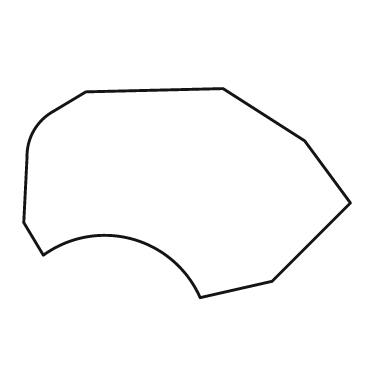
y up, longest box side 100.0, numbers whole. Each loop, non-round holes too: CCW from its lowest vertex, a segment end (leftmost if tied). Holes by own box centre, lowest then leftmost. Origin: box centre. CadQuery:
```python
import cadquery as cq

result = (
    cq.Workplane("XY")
    .moveTo(4.0, -32.0)
    .lineTo(26.0, -27.0)
    .lineTo(50.0, -3.0)
    .lineTo(36.0, 16.0)
    .lineTo(11.0, 32.0)
    .lineTo(-31.0, 31.0)
    .lineTo(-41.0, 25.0)
    .threePointArc((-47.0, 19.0), (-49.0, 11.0))
    .lineTo(-50.0, -9.0)
    .lineTo(-44.0, -19.0)
    .threePointArc((-17.0, -14.0), (4.0, -32.0))
    .close()
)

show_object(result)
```